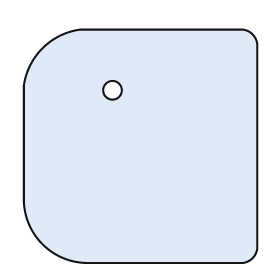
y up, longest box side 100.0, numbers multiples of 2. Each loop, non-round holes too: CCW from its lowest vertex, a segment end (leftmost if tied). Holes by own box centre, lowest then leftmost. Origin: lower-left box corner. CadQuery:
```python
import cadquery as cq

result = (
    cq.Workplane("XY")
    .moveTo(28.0, 0.0)
    .lineTo(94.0, 0.0)
    .threePointArc((98.0, 2.0), (100.0, 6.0))
    .lineTo(100.0, 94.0)
    .threePointArc((98.0, 98.0), (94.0, 100.0))
    .lineTo(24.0, 100.0)
    .threePointArc((8.0, 92.0), (0.0, 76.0))
    .lineTo(0.0, 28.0)
    .threePointArc((8.0, 8.0), (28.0, 0.0))
    .close()
    .moveTo(38.0, 74.0)
    .circle(4.0)
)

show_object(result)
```